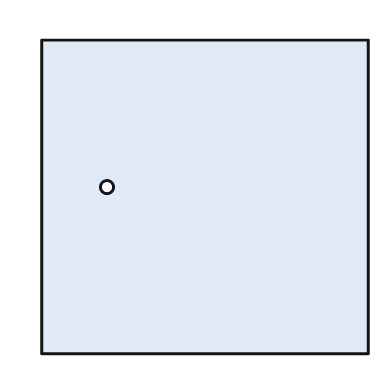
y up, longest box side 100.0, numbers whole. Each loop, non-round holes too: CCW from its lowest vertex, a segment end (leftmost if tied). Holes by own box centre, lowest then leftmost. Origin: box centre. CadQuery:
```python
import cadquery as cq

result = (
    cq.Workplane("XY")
    .moveTo(-50.0, -48.0)
    .lineTo(50.0, -48.0)
    .lineTo(50.0, 48.0)
    .lineTo(-50.0, 48.0)
    .close()
    .moveTo(-30.0, 3.0)
    .circle(2.0)
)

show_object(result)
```